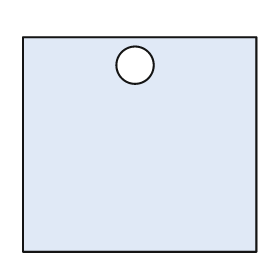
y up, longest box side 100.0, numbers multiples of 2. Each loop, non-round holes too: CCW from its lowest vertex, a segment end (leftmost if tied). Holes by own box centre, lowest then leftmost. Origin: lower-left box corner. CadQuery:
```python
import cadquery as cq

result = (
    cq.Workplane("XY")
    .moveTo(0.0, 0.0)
    .lineTo(100.0, 0.0)
    .lineTo(100.0, 92.0)
    .lineTo(0.0, 92.0)
    .close()
    .moveTo(48.0, 80.0)
    .circle(8.0)
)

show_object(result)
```